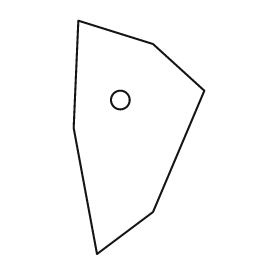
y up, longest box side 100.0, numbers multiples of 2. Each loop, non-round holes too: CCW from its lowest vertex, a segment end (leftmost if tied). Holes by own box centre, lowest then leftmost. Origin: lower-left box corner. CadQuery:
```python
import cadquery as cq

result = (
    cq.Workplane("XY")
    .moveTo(10.0, 0.0)
    .lineTo(34.0, 18.0)
    .lineTo(56.0, 70.0)
    .lineTo(34.0, 90.0)
    .lineTo(2.0, 100.0)
    .lineTo(0.0, 54.0)
    .close()
    .moveTo(20.0, 66.0)
    .circle(4.0)
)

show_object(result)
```